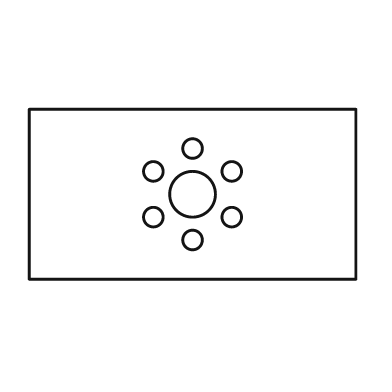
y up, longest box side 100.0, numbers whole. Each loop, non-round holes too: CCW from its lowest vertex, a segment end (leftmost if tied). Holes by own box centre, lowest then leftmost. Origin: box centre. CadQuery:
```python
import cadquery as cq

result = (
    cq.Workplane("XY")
    .moveTo(-50.0, -26.0)
    .lineTo(50.0, -26.0)
    .lineTo(50.0, 26.0)
    .lineTo(-50.0, 26.0)
    .close()
    .moveTo(0.0, -14.0)
    .circle(3.0)
    .moveTo(-12.0, -7.0)
    .circle(3.0)
    .moveTo(12.0, -7.0)
    .circle(3.0)
    .moveTo(0.0, 0.0)
    .circle(7.0)
    .moveTo(-12.0, 7.0)
    .circle(3.0)
    .moveTo(12.0, 7.0)
    .circle(3.0)
    .moveTo(0.0, 14.0)
    .circle(3.0)
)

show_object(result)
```